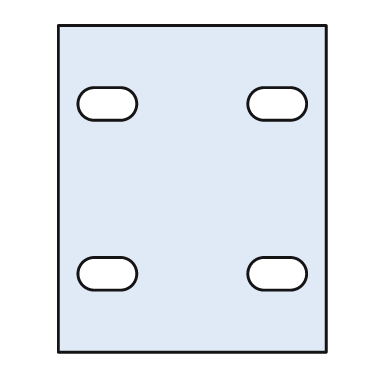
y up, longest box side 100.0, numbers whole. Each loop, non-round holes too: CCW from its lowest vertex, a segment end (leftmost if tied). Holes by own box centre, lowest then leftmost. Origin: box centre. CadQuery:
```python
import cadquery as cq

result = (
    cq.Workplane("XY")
    .moveTo(-41.0, -50.0)
    .lineTo(41.0, -50.0)
    .lineTo(41.0, 50.0)
    .lineTo(-41.0, 50.0)
    .close()
    .moveTo(-30.0, -31.0)
    .lineTo(-22.0, -31.0)
    .threePointArc((-17.0, -26.0), (-22.0, -21.0))
    .lineTo(-30.0, -21.0)
    .threePointArc((-35.0, -26.0), (-30.0, -31.0))
    .close()
    .moveTo(22.0, -31.0)
    .lineTo(30.0, -31.0)
    .threePointArc((35.0, -26.0), (30.0, -21.0))
    .lineTo(22.0, -21.0)
    .threePointArc((17.0, -26.0), (22.0, -31.0))
    .close()
    .moveTo(-30.0, 21.0)
    .lineTo(-22.0, 21.0)
    .threePointArc((-17.0, 26.0), (-22.0, 31.0))
    .lineTo(-30.0, 31.0)
    .threePointArc((-35.0, 26.0), (-30.0, 21.0))
    .close()
    .moveTo(22.0, 21.0)
    .lineTo(30.0, 21.0)
    .threePointArc((35.0, 26.0), (30.0, 31.0))
    .lineTo(22.0, 31.0)
    .threePointArc((17.0, 26.0), (22.0, 21.0))
    .close()
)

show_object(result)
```